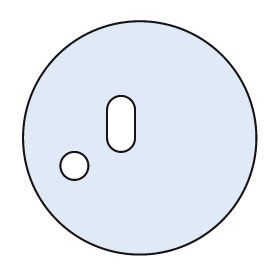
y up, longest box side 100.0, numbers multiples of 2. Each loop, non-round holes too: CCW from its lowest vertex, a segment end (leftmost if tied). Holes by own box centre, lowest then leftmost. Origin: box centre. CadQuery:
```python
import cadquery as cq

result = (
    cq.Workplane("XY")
    .moveTo(0.0, 0.0)
    .circle(50.0)
    .moveTo(-28.0, -12.0)
    .circle(6.0)
    .moveTo(-14.0, 0.0)
    .threePointArc((-8.0, -6.0), (-2.0, 0.0))
    .lineTo(-2.0, 12.0)
    .threePointArc((-8.0, 18.0), (-14.0, 12.0))
    .close()
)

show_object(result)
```